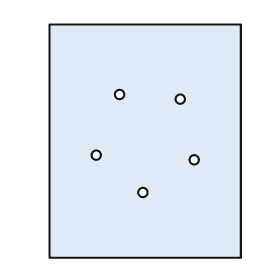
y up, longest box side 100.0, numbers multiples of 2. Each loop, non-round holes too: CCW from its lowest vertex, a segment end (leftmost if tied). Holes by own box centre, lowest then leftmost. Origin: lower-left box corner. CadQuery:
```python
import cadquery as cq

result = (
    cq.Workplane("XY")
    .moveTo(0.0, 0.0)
    .lineTo(82.0, 0.0)
    .lineTo(82.0, 100.0)
    .lineTo(0.0, 100.0)
    .close()
    .moveTo(40.0, 28.0)
    .circle(2.0)
    .moveTo(62.0, 42.0)
    .circle(2.0)
    .moveTo(20.0, 44.0)
    .circle(2.0)
    .moveTo(56.0, 68.0)
    .circle(2.0)
    .moveTo(30.0, 70.0)
    .circle(2.0)
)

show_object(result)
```